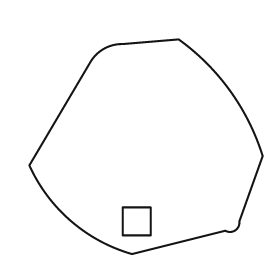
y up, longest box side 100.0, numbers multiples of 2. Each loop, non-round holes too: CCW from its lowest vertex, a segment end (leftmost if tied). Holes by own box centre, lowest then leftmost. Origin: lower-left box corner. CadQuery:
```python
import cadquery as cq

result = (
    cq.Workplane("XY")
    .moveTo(44.0, 0.0)
    .lineTo(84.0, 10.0)
    .threePointArc((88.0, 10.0), (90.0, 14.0))
    .lineTo(100.0, 42.0)
    .threePointArc((86.0, 70.0), (64.0, 92.0))
    .lineTo(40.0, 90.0)
    .threePointArc((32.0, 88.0), (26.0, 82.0))
    .lineTo(0.0, 38.0)
    .threePointArc((18.0, 14.0), (44.0, 0.0))
    .close()
    .moveTo(40.0, 8.0)
    .lineTo(52.0, 8.0)
    .lineTo(52.0, 20.0)
    .lineTo(40.0, 20.0)
    .close()
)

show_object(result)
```